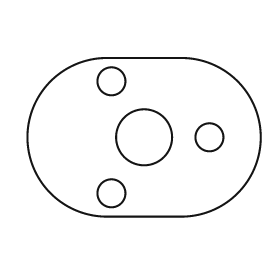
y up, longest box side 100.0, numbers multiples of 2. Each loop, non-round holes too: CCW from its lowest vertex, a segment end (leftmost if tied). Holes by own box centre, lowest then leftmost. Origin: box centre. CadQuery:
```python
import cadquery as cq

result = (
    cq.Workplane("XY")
    .moveTo(-16.0, -34.0)
    .lineTo(16.0, -34.0)
    .threePointArc((50.0, 0.0), (16.0, 34.0))
    .lineTo(-16.0, 34.0)
    .threePointArc((-50.0, 0.0), (-16.0, -34.0))
    .close()
    .moveTo(-14.0, -24.0)
    .circle(6.0)
    .moveTo(0.0, 0.0)
    .circle(12.0)
    .moveTo(28.0, 0.0)
    .circle(6.0)
    .moveTo(-14.0, 24.0)
    .circle(6.0)
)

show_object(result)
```